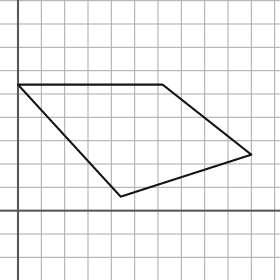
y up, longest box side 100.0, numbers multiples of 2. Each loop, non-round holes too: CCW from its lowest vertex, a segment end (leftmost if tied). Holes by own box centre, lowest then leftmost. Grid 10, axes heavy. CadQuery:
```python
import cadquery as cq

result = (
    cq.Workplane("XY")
    .moveTo(44.0, 6.0)
    .lineTo(100.0, 24.0)
    .lineTo(62.0, 54.0)
    .lineTo(0.0, 54.0)
    .close()
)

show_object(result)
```